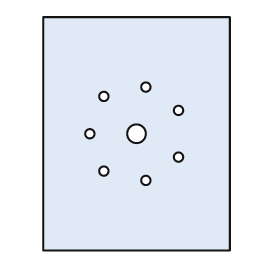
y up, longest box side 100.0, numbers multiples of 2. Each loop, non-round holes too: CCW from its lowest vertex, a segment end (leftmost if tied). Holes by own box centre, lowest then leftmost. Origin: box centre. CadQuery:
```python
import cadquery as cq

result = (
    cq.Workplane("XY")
    .moveTo(-40.0, -50.0)
    .lineTo(40.0, -50.0)
    .lineTo(40.0, 50.0)
    .lineTo(-40.0, 50.0)
    .close()
    .moveTo(4.0, -20.0)
    .circle(2.0)
    .moveTo(-14.0, -16.0)
    .circle(2.0)
    .moveTo(18.0, -10.0)
    .circle(2.0)
    .moveTo(-20.0, 0.0)
    .circle(2.0)
    .moveTo(0.0, 0.0)
    .circle(4.0)
    .moveTo(18.0, 10.0)
    .circle(2.0)
    .moveTo(-14.0, 16.0)
    .circle(2.0)
    .moveTo(4.0, 20.0)
    .circle(2.0)
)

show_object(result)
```